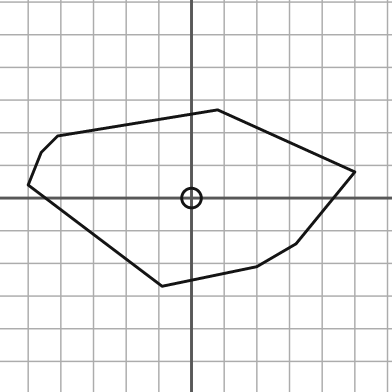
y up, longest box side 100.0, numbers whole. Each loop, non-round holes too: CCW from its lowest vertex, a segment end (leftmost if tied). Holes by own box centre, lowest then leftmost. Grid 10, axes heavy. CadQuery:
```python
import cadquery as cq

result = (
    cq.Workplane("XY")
    .moveTo(-9.0, -27.0)
    .lineTo(20.0, -21.0)
    .lineTo(32.0, -14.0)
    .lineTo(50.0, 8.0)
    .lineTo(8.0, 27.0)
    .lineTo(-41.0, 19.0)
    .lineTo(-46.0, 14.0)
    .lineTo(-50.0, 4.0)
    .close()
    .moveTo(0.0, 0.0)
    .circle(3.0)
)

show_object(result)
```